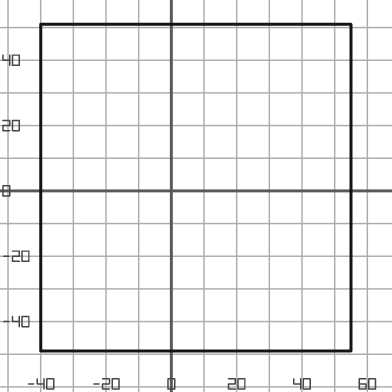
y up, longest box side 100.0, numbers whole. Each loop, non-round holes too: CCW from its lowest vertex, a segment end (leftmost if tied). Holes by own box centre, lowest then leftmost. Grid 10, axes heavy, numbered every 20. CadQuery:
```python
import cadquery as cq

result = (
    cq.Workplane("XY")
    .moveTo(-40.0, -49.0)
    .lineTo(55.0, -49.0)
    .lineTo(55.0, 51.0)
    .lineTo(-40.0, 51.0)
    .close()
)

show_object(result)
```